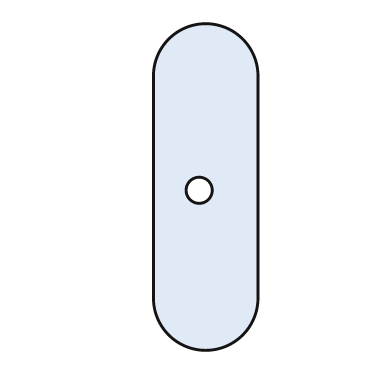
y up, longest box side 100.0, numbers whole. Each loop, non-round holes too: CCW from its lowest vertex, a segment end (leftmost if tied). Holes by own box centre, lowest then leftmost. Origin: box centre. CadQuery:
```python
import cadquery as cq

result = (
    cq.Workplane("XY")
    .moveTo(-16.0, -34.0)
    .threePointArc((0.0, -50.0), (16.0, -34.0))
    .lineTo(16.0, 34.0)
    .threePointArc((0.0, 50.0), (-16.0, 34.0))
    .close()
    .moveTo(-2.0, -1.0)
    .circle(4.0)
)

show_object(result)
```